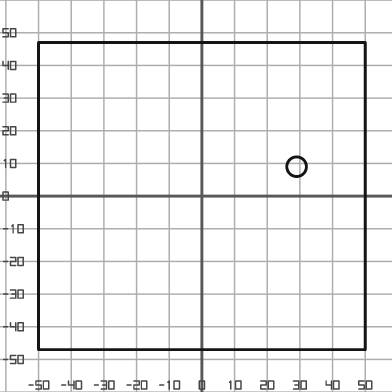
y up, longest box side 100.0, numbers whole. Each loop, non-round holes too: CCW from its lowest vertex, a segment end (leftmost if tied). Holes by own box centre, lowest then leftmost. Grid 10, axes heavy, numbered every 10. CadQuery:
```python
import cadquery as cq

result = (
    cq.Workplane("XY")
    .moveTo(-50.0, -47.0)
    .lineTo(50.0, -47.0)
    .lineTo(50.0, 47.0)
    .lineTo(-50.0, 47.0)
    .close()
    .moveTo(29.0, 9.0)
    .circle(3.0)
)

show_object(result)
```